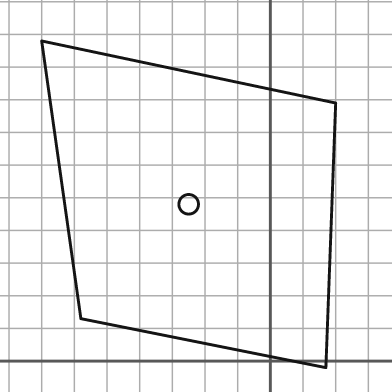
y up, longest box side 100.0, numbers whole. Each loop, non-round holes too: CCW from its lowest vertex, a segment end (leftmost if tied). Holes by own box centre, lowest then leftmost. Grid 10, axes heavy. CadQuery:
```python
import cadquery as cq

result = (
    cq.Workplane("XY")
    .moveTo(17.0, -2.0)
    .lineTo(20.0, 79.0)
    .lineTo(-70.0, 98.0)
    .lineTo(-58.0, 13.0)
    .close()
    .moveTo(-25.0, 48.0)
    .circle(3.0)
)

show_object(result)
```